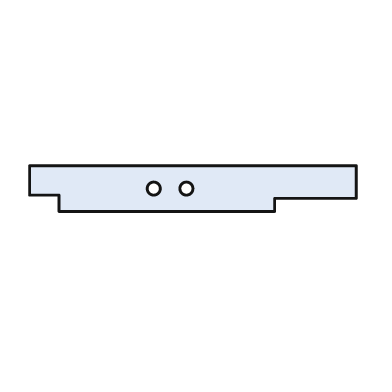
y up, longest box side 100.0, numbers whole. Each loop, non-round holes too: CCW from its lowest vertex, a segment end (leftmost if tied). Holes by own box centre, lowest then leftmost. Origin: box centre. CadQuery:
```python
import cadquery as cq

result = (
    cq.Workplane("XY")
    .moveTo(-41.0, -7.0)
    .lineTo(25.0, -7.0)
    .lineTo(25.0, -3.0)
    .lineTo(50.0, -3.0)
    .lineTo(50.0, 7.0)
    .lineTo(-50.0, 7.0)
    .lineTo(-50.0, -2.0)
    .lineTo(-41.0, -2.0)
    .close()
    .moveTo(-12.0, 0.0)
    .circle(2.0)
    .moveTo(-2.0, 0.0)
    .circle(2.0)
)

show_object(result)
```